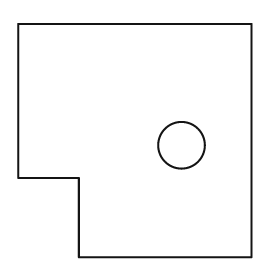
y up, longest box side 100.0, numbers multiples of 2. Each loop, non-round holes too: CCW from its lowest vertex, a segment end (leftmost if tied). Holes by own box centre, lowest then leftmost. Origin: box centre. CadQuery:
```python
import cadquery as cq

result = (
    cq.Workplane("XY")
    .moveTo(-24.0, -50.0)
    .lineTo(50.0, -50.0)
    .lineTo(50.0, 50.0)
    .lineTo(-50.0, 50.0)
    .lineTo(-50.0, -16.0)
    .lineTo(-24.0, -16.0)
    .close()
    .moveTo(20.0, -2.0)
    .circle(10.0)
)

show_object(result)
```